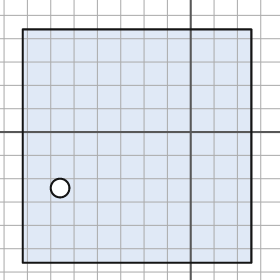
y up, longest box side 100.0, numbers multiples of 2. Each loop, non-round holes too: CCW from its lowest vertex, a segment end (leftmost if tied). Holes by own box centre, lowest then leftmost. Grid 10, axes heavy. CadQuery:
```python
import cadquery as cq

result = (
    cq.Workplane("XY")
    .moveTo(-72.0, -56.0)
    .lineTo(26.0, -56.0)
    .lineTo(26.0, 44.0)
    .lineTo(-72.0, 44.0)
    .close()
    .moveTo(-56.0, -24.0)
    .circle(4.0)
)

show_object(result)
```